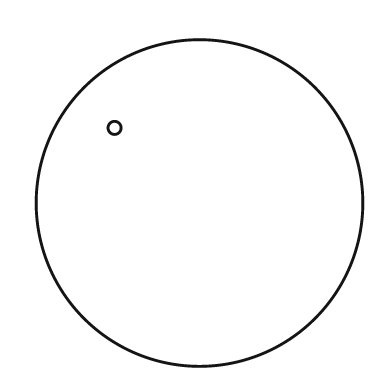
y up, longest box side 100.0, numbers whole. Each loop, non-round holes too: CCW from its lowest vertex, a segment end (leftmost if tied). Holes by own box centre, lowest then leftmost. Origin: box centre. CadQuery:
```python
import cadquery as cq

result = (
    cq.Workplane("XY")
    .moveTo(0.0, 0.0)
    .circle(50.0)
    .moveTo(-26.0, 23.0)
    .circle(2.0)
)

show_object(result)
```